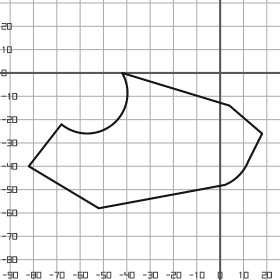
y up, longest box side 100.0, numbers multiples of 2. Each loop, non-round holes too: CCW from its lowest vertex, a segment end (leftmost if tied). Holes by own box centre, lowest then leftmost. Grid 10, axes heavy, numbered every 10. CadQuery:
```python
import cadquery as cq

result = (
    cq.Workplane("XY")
    .moveTo(-52.0, -58.0)
    .lineTo(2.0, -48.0)
    .threePointArc((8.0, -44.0), (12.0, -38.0))
    .lineTo(18.0, -26.0)
    .lineTo(4.0, -14.0)
    .lineTo(-42.0, 0.0)
    .threePointArc((-46.0, -22.0), (-68.0, -22.0))
    .lineTo(-82.0, -40.0)
    .close()
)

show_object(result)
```